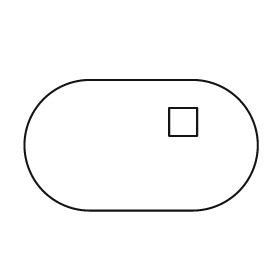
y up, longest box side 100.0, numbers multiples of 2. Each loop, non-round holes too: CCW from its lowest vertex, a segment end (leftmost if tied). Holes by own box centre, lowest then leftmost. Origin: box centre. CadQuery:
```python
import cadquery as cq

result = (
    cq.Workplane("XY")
    .moveTo(-22.0, -28.0)
    .lineTo(22.0, -28.0)
    .threePointArc((50.0, 0.0), (22.0, 28.0))
    .lineTo(-22.0, 28.0)
    .threePointArc((-50.0, 0.0), (-22.0, -28.0))
    .close()
    .moveTo(12.0, 4.0)
    .lineTo(24.0, 4.0)
    .lineTo(24.0, 16.0)
    .lineTo(12.0, 16.0)
    .close()
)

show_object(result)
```